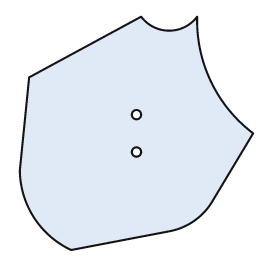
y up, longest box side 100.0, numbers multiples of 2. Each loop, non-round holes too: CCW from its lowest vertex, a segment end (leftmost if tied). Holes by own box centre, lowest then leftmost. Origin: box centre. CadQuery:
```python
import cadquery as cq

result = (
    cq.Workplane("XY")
    .moveTo(-28.0, -50.0)
    .lineTo(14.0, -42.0)
    .threePointArc((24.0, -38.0), (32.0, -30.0))
    .lineTo(50.0, 0.0)
    .threePointArc((32.0, 22.0), (26.0, 50.0))
    .threePointArc((14.0, 44.0), (2.0, 50.0))
    .lineTo(-46.0, 24.0)
    .lineTo(-50.0, -16.0)
    .threePointArc((-44.0, -36.0), (-28.0, -50.0))
    .close()
    .moveTo(0.0, -8.0)
    .circle(2.0)
    .moveTo(0.0, 8.0)
    .circle(2.0)
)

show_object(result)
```